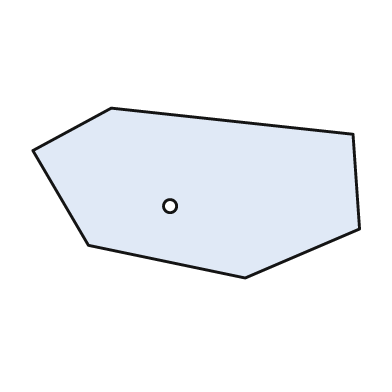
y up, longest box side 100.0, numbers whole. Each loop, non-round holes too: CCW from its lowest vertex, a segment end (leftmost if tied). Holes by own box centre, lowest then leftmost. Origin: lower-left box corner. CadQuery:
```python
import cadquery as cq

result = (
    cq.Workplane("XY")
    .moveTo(65.0, 0.0)
    .lineTo(100.0, 15.0)
    .lineTo(98.0, 44.0)
    .lineTo(24.0, 52.0)
    .lineTo(0.0, 39.0)
    .lineTo(17.0, 10.0)
    .close()
    .moveTo(42.0, 22.0)
    .circle(2.0)
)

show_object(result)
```